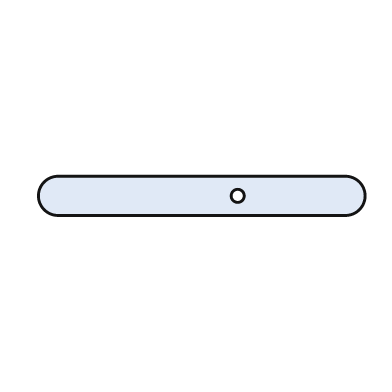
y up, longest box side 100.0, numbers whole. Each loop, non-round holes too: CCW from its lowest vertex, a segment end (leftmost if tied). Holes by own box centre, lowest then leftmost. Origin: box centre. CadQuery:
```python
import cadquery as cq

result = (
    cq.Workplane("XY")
    .moveTo(-44.0, -6.0)
    .lineTo(44.0, -6.0)
    .threePointArc((50.0, 0.0), (44.0, 6.0))
    .lineTo(-44.0, 6.0)
    .threePointArc((-50.0, 0.0), (-44.0, -6.0))
    .close()
    .moveTo(11.0, 0.0)
    .circle(2.0)
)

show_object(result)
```